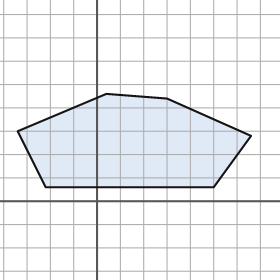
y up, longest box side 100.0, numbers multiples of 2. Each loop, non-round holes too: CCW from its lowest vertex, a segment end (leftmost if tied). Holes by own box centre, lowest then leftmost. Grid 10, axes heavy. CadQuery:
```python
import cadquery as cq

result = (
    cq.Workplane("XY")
    .moveTo(-22.0, 6.0)
    .lineTo(50.0, 6.0)
    .lineTo(66.0, 28.0)
    .lineTo(30.0, 44.0)
    .lineTo(4.0, 46.0)
    .lineTo(-34.0, 30.0)
    .close()
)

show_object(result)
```